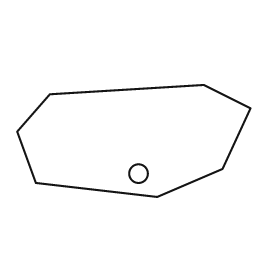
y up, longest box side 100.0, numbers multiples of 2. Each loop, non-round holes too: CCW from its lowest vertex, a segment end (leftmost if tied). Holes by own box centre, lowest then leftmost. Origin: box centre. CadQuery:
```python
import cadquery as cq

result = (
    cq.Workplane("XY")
    .moveTo(10.0, -24.0)
    .lineTo(38.0, -12.0)
    .lineTo(50.0, 14.0)
    .lineTo(30.0, 24.0)
    .lineTo(-36.0, 20.0)
    .lineTo(-50.0, 4.0)
    .lineTo(-42.0, -18.0)
    .close()
    .moveTo(2.0, -14.0)
    .circle(4.0)
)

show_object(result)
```